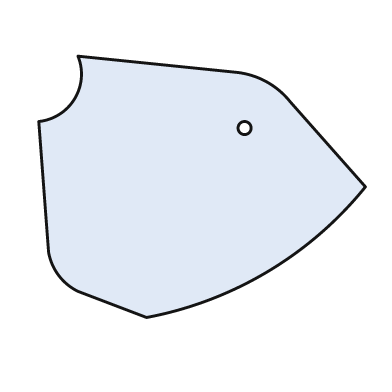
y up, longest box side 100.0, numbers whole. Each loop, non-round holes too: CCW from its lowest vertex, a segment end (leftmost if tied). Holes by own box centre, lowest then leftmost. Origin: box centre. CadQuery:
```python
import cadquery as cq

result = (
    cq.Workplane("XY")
    .moveTo(-17.0, -40.0)
    .threePointArc((20.0, -26.0), (50.0, 0.0))
    .lineTo(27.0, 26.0)
    .threePointArc((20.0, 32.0), (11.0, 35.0))
    .lineTo(-38.0, 40.0)
    .threePointArc((-39.0, 27.0), (-50.0, 20.0))
    .lineTo(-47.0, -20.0)
    .threePointArc((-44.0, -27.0), (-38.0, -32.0))
    .close()
    .moveTo(13.0, 18.0)
    .circle(2.0)
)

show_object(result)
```